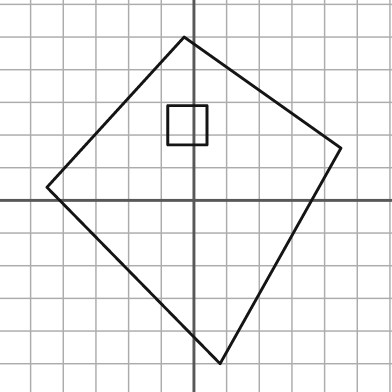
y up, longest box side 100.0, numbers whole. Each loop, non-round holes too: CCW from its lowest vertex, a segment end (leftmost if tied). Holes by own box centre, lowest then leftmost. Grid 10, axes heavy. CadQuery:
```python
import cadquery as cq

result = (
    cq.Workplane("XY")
    .moveTo(8.0, -50.0)
    .lineTo(45.0, 16.0)
    .lineTo(-3.0, 50.0)
    .lineTo(-45.0, 4.0)
    .close()
    .moveTo(-8.0, 17.0)
    .lineTo(4.0, 17.0)
    .lineTo(4.0, 29.0)
    .lineTo(-8.0, 29.0)
    .close()
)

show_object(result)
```